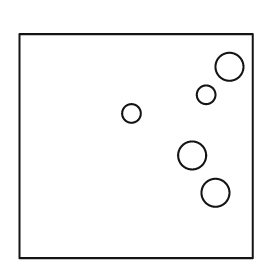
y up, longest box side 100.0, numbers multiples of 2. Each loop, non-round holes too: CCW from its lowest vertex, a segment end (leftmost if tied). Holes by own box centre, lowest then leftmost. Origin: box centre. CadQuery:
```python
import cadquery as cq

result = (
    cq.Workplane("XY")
    .moveTo(-50.0, -48.0)
    .lineTo(50.0, -48.0)
    .lineTo(50.0, 48.0)
    .lineTo(-50.0, 48.0)
    .close()
    .moveTo(34.0, -20.0)
    .circle(6.0)
    .moveTo(24.0, -4.0)
    .circle(6.0)
    .moveTo(-2.0, 14.0)
    .circle(4.0)
    .moveTo(30.0, 22.0)
    .circle(4.0)
    .moveTo(40.0, 34.0)
    .circle(6.0)
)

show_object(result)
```